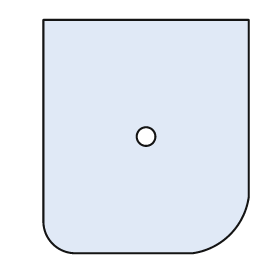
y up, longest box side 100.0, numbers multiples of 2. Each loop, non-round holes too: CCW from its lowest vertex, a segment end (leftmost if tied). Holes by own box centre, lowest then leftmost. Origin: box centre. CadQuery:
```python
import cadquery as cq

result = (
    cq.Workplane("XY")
    .moveTo(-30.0, -50.0)
    .lineTo(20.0, -50.0)
    .threePointArc((36.0, -42.0), (44.0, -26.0))
    .lineTo(44.0, 50.0)
    .lineTo(-44.0, 50.0)
    .lineTo(-44.0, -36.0)
    .threePointArc((-40.0, -46.0), (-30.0, -50.0))
    .close()
    .moveTo(0.0, 0.0)
    .circle(4.0)
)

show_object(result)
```